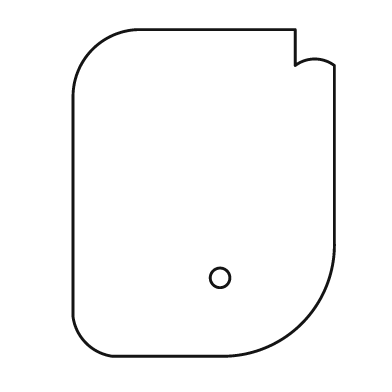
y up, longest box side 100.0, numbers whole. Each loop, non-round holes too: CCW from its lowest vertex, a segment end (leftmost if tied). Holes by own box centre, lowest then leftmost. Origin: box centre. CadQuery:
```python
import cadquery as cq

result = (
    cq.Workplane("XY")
    .moveTo(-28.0, -50.0)
    .lineTo(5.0, -50.0)
    .threePointArc((30.0, -40.0), (40.0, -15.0))
    .lineTo(40.0, 39.0)
    .threePointArc((34.0, 41.0), (28.0, 39.0))
    .lineTo(28.0, 50.0)
    .lineTo(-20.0, 50.0)
    .threePointArc((-34.0, 44.0), (-40.0, 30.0))
    .lineTo(-40.0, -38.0)
    .threePointArc((-36.0, -46.0), (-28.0, -50.0))
    .close()
    .moveTo(5.0, -26.0)
    .circle(3.0)
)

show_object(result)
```